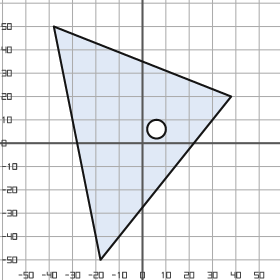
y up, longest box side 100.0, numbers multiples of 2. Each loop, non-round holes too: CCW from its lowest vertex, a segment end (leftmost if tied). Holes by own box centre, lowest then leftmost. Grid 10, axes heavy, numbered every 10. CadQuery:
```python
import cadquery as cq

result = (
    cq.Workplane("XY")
    .moveTo(-18.0, -50.0)
    .lineTo(38.0, 20.0)
    .lineTo(-38.0, 50.0)
    .close()
    .moveTo(6.0, 6.0)
    .circle(4.0)
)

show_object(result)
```